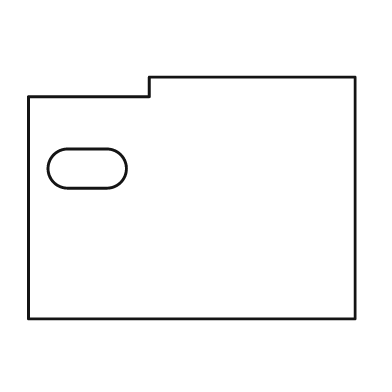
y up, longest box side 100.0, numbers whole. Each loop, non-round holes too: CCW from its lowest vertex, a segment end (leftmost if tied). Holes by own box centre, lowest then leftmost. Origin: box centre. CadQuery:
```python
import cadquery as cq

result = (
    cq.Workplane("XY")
    .moveTo(-50.0, -37.0)
    .lineTo(50.0, -37.0)
    .lineTo(50.0, 37.0)
    .lineTo(-13.0, 37.0)
    .lineTo(-13.0, 31.0)
    .lineTo(-50.0, 31.0)
    .close()
    .moveTo(-38.0, 3.0)
    .lineTo(-26.0, 3.0)
    .threePointArc((-20.0, 9.0), (-26.0, 15.0))
    .lineTo(-38.0, 15.0)
    .threePointArc((-44.0, 9.0), (-38.0, 3.0))
    .close()
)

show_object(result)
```